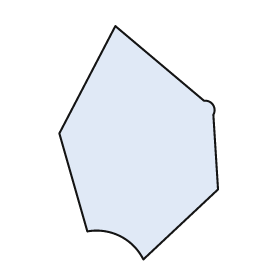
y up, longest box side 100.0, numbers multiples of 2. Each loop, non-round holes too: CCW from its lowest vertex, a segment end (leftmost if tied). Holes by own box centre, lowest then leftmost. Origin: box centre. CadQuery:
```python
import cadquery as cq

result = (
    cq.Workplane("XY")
    .moveTo(2.0, -50.0)
    .lineTo(34.0, -20.0)
    .lineTo(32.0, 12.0)
    .threePointArc((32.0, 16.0), (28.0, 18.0))
    .lineTo(-10.0, 50.0)
    .lineTo(-34.0, 4.0)
    .lineTo(-22.0, -38.0)
    .threePointArc((-8.0, -40.0), (2.0, -50.0))
    .close()
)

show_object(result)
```